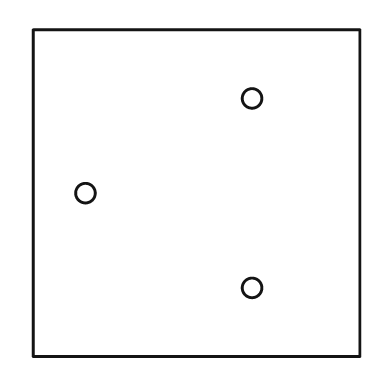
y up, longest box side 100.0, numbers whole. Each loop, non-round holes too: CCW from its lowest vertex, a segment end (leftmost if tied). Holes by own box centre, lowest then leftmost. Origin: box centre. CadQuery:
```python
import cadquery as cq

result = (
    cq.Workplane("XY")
    .moveTo(-50.0, -50.0)
    .lineTo(50.0, -50.0)
    .lineTo(50.0, 50.0)
    .lineTo(-50.0, 50.0)
    .close()
    .moveTo(17.0, -29.0)
    .circle(3.0)
    .moveTo(-34.0, 0.0)
    .circle(3.0)
    .moveTo(17.0, 29.0)
    .circle(3.0)
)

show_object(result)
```